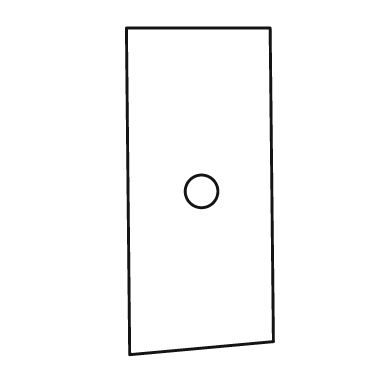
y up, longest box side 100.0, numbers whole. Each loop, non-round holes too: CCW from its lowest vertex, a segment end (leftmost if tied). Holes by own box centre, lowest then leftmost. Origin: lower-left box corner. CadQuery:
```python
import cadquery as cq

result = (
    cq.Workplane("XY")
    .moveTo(1.0, 0.0)
    .lineTo(45.0, 4.0)
    .lineTo(44.0, 100.0)
    .lineTo(0.0, 100.0)
    .close()
    .moveTo(23.0, 50.0)
    .circle(5.0)
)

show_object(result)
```